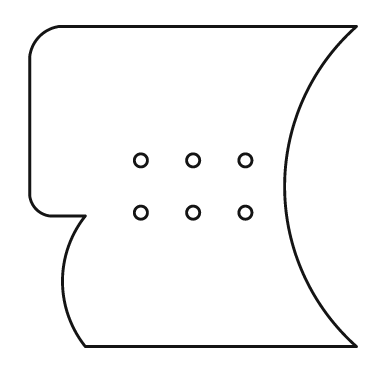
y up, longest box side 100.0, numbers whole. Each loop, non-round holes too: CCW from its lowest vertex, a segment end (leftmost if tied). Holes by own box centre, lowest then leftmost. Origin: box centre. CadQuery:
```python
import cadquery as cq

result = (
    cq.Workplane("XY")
    .moveTo(-33.0, -49.0)
    .lineTo(50.0, -49.0)
    .threePointArc((28.0, 0.0), (50.0, 49.0))
    .lineTo(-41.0, 49.0)
    .threePointArc((-47.0, 46.0), (-50.0, 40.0))
    .lineTo(-50.0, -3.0)
    .threePointArc((-48.0, -7.0), (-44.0, -9.0))
    .lineTo(-33.0, -9.0)
    .threePointArc((-40.0, -29.0), (-33.0, -49.0))
    .close()
    .moveTo(-16.0, -8.0)
    .circle(2.0)
    .moveTo(0.0, -8.0)
    .circle(2.0)
    .moveTo(16.0, -8.0)
    .circle(2.0)
    .moveTo(-16.0, 8.0)
    .circle(2.0)
    .moveTo(0.0, 8.0)
    .circle(2.0)
    .moveTo(16.0, 8.0)
    .circle(2.0)
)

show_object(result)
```